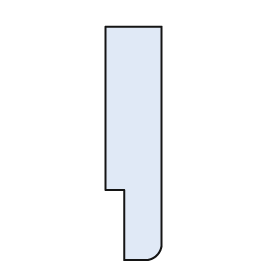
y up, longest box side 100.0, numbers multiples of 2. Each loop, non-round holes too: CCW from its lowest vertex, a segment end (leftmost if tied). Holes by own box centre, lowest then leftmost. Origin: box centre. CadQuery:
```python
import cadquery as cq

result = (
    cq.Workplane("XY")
    .moveTo(-4.0, -50.0)
    .lineTo(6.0, -50.0)
    .threePointArc((10.0, -48.0), (12.0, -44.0))
    .lineTo(12.0, 50.0)
    .lineTo(-12.0, 50.0)
    .lineTo(-12.0, -20.0)
    .lineTo(-4.0, -20.0)
    .close()
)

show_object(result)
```